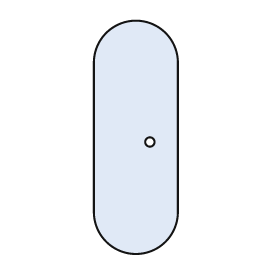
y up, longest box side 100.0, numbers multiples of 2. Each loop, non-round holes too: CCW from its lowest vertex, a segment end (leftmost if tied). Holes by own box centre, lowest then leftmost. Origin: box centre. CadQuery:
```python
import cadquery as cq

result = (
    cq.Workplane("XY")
    .moveTo(-18.0, -32.0)
    .threePointArc((0.0, -50.0), (18.0, -32.0))
    .lineTo(18.0, 32.0)
    .threePointArc((0.0, 50.0), (-18.0, 32.0))
    .close()
    .moveTo(6.0, -2.0)
    .circle(2.0)
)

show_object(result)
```